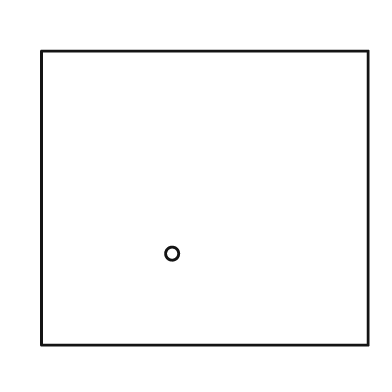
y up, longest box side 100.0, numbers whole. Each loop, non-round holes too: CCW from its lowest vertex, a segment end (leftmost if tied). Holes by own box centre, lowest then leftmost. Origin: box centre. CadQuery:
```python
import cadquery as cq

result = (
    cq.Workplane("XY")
    .moveTo(-50.0, -45.0)
    .lineTo(50.0, -45.0)
    .lineTo(50.0, 45.0)
    .lineTo(-50.0, 45.0)
    .close()
    .moveTo(-10.0, -17.0)
    .circle(2.0)
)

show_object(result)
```